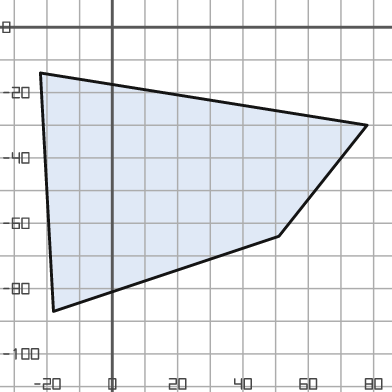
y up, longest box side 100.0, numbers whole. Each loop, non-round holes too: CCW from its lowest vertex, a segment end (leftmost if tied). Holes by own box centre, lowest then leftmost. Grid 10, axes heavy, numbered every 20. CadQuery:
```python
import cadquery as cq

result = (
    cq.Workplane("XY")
    .moveTo(-18.0, -87.0)
    .lineTo(51.0, -64.0)
    .lineTo(78.0, -30.0)
    .lineTo(-22.0, -14.0)
    .close()
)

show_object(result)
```